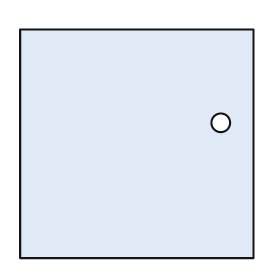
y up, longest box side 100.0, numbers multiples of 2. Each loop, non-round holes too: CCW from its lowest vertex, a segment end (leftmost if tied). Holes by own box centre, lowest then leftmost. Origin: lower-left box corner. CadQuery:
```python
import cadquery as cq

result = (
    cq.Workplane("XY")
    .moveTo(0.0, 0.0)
    .lineTo(100.0, 0.0)
    .lineTo(100.0, 98.0)
    .lineTo(0.0, 98.0)
    .close()
    .moveTo(86.0, 58.0)
    .circle(4.0)
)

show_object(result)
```